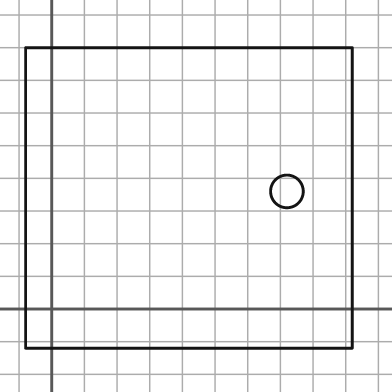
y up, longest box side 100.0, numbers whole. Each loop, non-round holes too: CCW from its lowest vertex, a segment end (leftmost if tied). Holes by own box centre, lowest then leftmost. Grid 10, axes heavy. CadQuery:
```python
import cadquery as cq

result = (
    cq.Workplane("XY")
    .moveTo(-8.0, -12.0)
    .lineTo(92.0, -12.0)
    .lineTo(92.0, 80.0)
    .lineTo(-8.0, 80.0)
    .close()
    .moveTo(72.0, 36.0)
    .circle(5.0)
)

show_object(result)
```